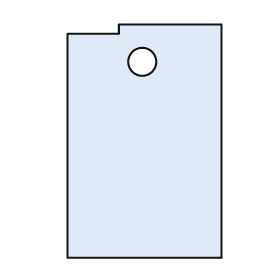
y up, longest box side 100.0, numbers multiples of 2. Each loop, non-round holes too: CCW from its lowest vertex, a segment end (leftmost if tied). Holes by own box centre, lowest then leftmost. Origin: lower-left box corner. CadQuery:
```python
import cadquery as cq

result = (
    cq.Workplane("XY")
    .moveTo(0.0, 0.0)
    .lineTo(66.0, 0.0)
    .lineTo(66.0, 100.0)
    .lineTo(22.0, 100.0)
    .lineTo(22.0, 96.0)
    .lineTo(0.0, 96.0)
    .close()
    .moveTo(32.0, 84.0)
    .circle(6.0)
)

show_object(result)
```